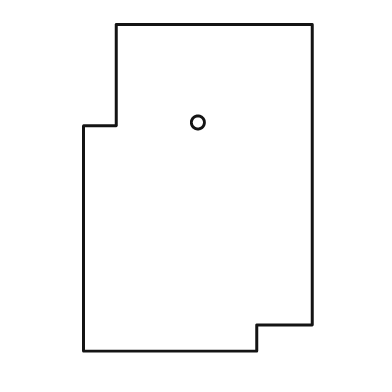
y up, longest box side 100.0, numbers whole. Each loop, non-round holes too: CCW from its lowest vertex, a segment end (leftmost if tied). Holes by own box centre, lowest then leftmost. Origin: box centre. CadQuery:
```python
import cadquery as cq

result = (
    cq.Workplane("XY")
    .moveTo(-35.0, -50.0)
    .lineTo(18.0, -50.0)
    .lineTo(18.0, -42.0)
    .lineTo(35.0, -42.0)
    .lineTo(35.0, 50.0)
    .lineTo(-25.0, 50.0)
    .lineTo(-25.0, 19.0)
    .lineTo(-35.0, 19.0)
    .close()
    .moveTo(0.0, 20.0)
    .circle(2.0)
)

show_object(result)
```